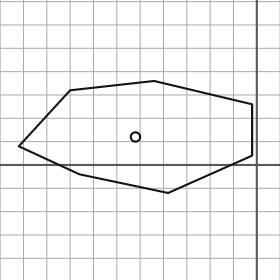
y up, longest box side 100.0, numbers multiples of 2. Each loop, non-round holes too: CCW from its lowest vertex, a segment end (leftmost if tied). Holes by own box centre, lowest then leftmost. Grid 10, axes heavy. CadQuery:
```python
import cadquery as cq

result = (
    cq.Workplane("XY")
    .moveTo(-38.0, -12.0)
    .lineTo(-2.0, 4.0)
    .lineTo(-2.0, 26.0)
    .lineTo(-44.0, 36.0)
    .lineTo(-80.0, 32.0)
    .lineTo(-102.0, 8.0)
    .lineTo(-76.0, -4.0)
    .close()
    .moveTo(-52.0, 12.0)
    .circle(2.0)
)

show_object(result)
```